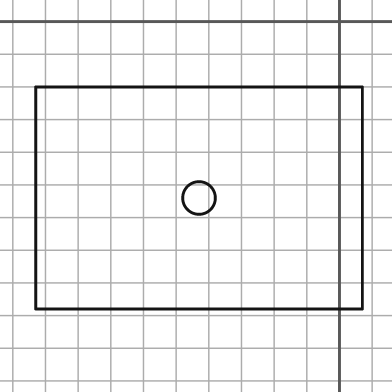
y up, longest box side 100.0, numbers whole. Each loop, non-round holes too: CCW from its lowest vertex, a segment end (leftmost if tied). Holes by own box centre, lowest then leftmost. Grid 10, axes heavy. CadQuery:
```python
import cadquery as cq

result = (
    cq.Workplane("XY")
    .moveTo(-93.0, -88.0)
    .lineTo(7.0, -88.0)
    .lineTo(7.0, -20.0)
    .lineTo(-93.0, -20.0)
    .close()
    .moveTo(-43.0, -54.0)
    .circle(5.0)
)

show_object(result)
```